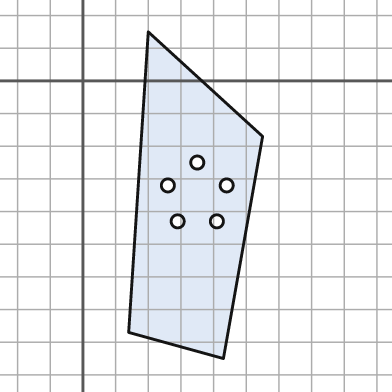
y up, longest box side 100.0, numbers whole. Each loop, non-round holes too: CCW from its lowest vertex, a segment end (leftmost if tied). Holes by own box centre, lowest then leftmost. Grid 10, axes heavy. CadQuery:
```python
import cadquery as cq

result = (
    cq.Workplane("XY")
    .moveTo(43.0, -85.0)
    .lineTo(55.0, -17.0)
    .lineTo(20.0, 15.0)
    .lineTo(14.0, -77.0)
    .close()
    .moveTo(29.0, -43.0)
    .circle(2.0)
    .moveTo(41.0, -43.0)
    .circle(2.0)
    .moveTo(26.0, -32.0)
    .circle(2.0)
    .moveTo(44.0, -32.0)
    .circle(2.0)
    .moveTo(35.0, -25.0)
    .circle(2.0)
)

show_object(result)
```